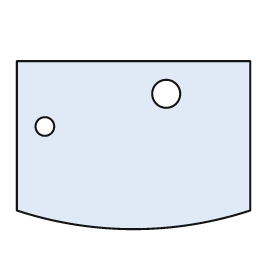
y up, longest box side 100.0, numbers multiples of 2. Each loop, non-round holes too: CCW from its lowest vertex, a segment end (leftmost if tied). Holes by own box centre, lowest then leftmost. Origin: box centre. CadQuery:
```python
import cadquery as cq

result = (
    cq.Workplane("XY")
    .moveTo(-50.0, -28.0)
    .threePointArc((0.0, -36.0), (50.0, -28.0))
    .lineTo(50.0, 36.0)
    .lineTo(-50.0, 36.0)
    .close()
    .moveTo(-38.0, 8.0)
    .circle(4.0)
    .moveTo(14.0, 22.0)
    .circle(6.0)
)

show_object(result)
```